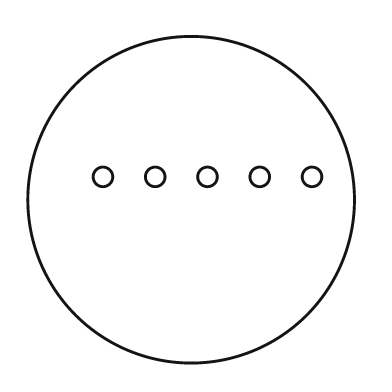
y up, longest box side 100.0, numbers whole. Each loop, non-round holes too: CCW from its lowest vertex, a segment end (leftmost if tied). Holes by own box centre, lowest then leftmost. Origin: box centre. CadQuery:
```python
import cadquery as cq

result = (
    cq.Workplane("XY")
    .moveTo(0.0, 0.0)
    .circle(50.0)
    .moveTo(-27.0, 7.0)
    .circle(3.0)
    .moveTo(-11.0, 7.0)
    .circle(3.0)
    .moveTo(5.0, 7.0)
    .circle(3.0)
    .moveTo(21.0, 7.0)
    .circle(3.0)
    .moveTo(37.0, 7.0)
    .circle(3.0)
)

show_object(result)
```